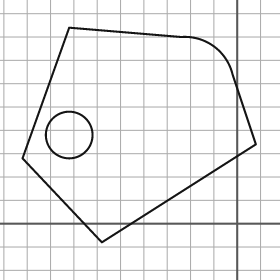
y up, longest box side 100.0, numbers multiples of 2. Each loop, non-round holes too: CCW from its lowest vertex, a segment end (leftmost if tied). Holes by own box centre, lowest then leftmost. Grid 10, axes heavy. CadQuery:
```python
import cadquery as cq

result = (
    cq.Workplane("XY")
    .moveTo(-58.0, -8.0)
    .lineTo(8.0, 34.0)
    .lineTo(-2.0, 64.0)
    .threePointArc((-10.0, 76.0), (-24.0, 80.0))
    .lineTo(-72.0, 84.0)
    .lineTo(-92.0, 28.0)
    .close()
    .moveTo(-72.0, 38.0)
    .circle(10.0)
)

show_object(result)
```